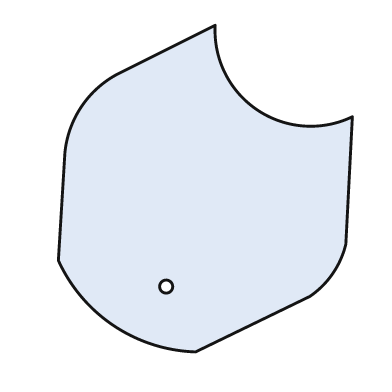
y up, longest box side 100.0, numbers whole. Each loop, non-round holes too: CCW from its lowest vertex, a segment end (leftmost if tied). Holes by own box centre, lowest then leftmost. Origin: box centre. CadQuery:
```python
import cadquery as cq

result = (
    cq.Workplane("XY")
    .moveTo(-3.0, -50.0)
    .lineTo(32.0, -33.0)
    .threePointArc((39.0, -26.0), (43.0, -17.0))
    .lineTo(45.0, 22.0)
    .threePointArc((16.0, 24.0), (3.0, 50.0))
    .lineTo(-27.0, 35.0)
    .threePointArc((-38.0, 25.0), (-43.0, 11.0))
    .lineTo(-45.0, -22.0)
    .threePointArc((-28.0, -42.0), (-3.0, -50.0))
    .close()
    .moveTo(-12.0, -30.0)
    .circle(2.0)
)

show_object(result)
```